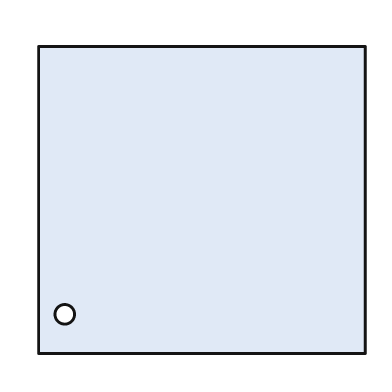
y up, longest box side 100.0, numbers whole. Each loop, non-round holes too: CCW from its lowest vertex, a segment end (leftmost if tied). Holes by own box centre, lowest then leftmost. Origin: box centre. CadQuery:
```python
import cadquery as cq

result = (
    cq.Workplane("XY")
    .moveTo(-50.0, -47.0)
    .lineTo(50.0, -47.0)
    .lineTo(50.0, 47.0)
    .lineTo(-50.0, 47.0)
    .close()
    .moveTo(-42.0, -35.0)
    .circle(3.0)
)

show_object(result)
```